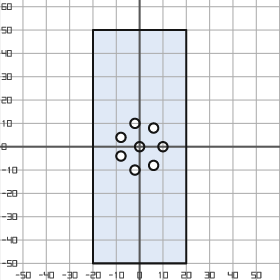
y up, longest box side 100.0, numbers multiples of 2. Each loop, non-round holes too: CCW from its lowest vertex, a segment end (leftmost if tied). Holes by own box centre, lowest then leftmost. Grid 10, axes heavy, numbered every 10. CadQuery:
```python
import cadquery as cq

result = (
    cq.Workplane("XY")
    .moveTo(-20.0, -50.0)
    .lineTo(20.0, -50.0)
    .lineTo(20.0, 50.0)
    .lineTo(-20.0, 50.0)
    .close()
    .moveTo(-2.0, -10.0)
    .circle(2.0)
    .moveTo(6.0, -8.0)
    .circle(2.0)
    .moveTo(-8.0, -4.0)
    .circle(2.0)
    .moveTo(0.0, 0.0)
    .circle(2.0)
    .moveTo(10.0, 0.0)
    .circle(2.0)
    .moveTo(-8.0, 4.0)
    .circle(2.0)
    .moveTo(6.0, 8.0)
    .circle(2.0)
    .moveTo(-2.0, 10.0)
    .circle(2.0)
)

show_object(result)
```